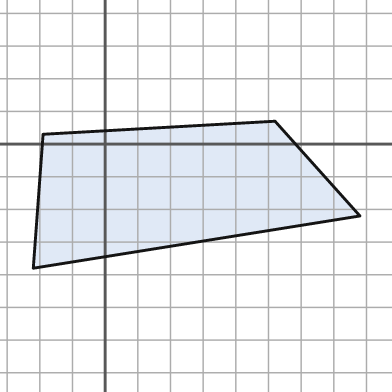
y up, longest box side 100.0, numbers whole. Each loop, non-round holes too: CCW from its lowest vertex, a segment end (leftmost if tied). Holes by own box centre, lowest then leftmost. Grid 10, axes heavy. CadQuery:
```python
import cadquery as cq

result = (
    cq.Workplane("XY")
    .moveTo(-22.0, -38.0)
    .lineTo(78.0, -22.0)
    .lineTo(52.0, 7.0)
    .lineTo(-19.0, 3.0)
    .close()
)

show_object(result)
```